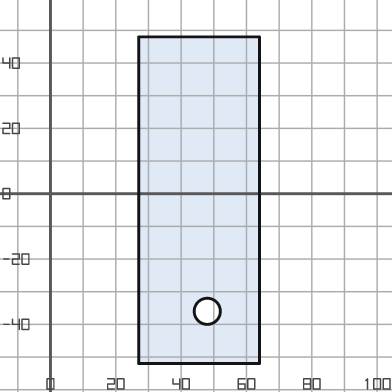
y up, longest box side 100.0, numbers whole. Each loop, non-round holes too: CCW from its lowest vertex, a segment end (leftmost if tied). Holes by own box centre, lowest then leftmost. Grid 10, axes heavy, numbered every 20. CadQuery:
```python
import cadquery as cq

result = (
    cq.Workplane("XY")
    .moveTo(27.0, -52.0)
    .lineTo(64.0, -52.0)
    .lineTo(64.0, 48.0)
    .lineTo(27.0, 48.0)
    .close()
    .moveTo(48.0, -36.0)
    .circle(4.0)
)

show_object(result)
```